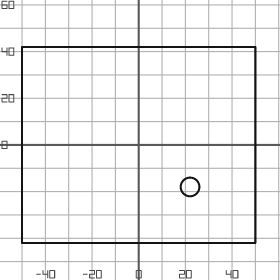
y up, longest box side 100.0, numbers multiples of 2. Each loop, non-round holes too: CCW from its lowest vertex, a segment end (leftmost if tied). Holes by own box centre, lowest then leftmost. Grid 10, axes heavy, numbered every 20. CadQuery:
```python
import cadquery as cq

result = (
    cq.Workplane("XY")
    .moveTo(-50.0, -42.0)
    .lineTo(50.0, -42.0)
    .lineTo(50.0, 42.0)
    .lineTo(-50.0, 42.0)
    .close()
    .moveTo(22.0, -18.0)
    .circle(4.0)
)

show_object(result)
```